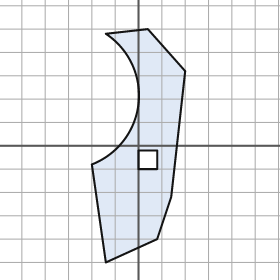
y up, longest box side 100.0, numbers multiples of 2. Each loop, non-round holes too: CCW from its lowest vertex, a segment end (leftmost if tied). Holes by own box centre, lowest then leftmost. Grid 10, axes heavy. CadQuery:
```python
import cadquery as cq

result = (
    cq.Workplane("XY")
    .moveTo(-14.0, -50.0)
    .lineTo(8.0, -40.0)
    .lineTo(14.0, -22.0)
    .lineTo(20.0, 32.0)
    .lineTo(4.0, 50.0)
    .lineTo(-14.0, 48.0)
    .threePointArc((0.0, 18.0), (-20.0, -8.0))
    .close()
    .moveTo(0.0, -10.0)
    .lineTo(8.0, -10.0)
    .lineTo(8.0, -2.0)
    .lineTo(0.0, -2.0)
    .close()
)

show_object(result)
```